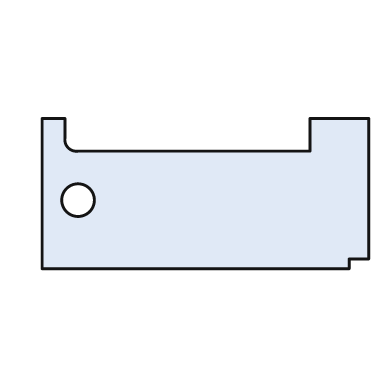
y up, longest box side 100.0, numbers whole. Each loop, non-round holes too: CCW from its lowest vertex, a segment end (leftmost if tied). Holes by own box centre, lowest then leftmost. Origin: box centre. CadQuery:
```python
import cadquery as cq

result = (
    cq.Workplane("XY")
    .moveTo(-50.0, -23.0)
    .lineTo(44.0, -23.0)
    .lineTo(44.0, -20.0)
    .lineTo(50.0, -20.0)
    .lineTo(50.0, 23.0)
    .lineTo(32.0, 23.0)
    .lineTo(32.0, 13.0)
    .lineTo(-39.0, 13.0)
    .threePointArc((-42.0, 14.0), (-43.0, 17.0))
    .lineTo(-43.0, 23.0)
    .lineTo(-50.0, 23.0)
    .close()
    .moveTo(-39.0, -2.0)
    .circle(5.0)
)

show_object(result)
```